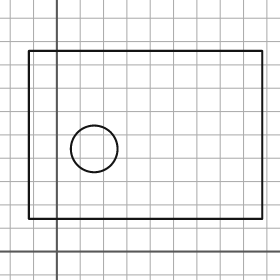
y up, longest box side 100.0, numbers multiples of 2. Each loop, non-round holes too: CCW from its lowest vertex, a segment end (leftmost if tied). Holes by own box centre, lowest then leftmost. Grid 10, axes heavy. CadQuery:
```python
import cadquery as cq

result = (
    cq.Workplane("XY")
    .moveTo(-12.0, 14.0)
    .lineTo(88.0, 14.0)
    .lineTo(88.0, 86.0)
    .lineTo(-12.0, 86.0)
    .close()
    .moveTo(16.0, 44.0)
    .circle(10.0)
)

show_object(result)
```